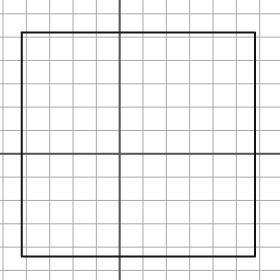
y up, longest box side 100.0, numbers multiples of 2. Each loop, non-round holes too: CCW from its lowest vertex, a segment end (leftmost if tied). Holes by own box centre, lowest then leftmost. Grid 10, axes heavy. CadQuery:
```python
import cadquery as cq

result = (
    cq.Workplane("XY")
    .moveTo(-42.0, -44.0)
    .lineTo(58.0, -44.0)
    .lineTo(58.0, 52.0)
    .lineTo(-42.0, 52.0)
    .close()
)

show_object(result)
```